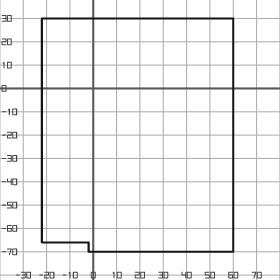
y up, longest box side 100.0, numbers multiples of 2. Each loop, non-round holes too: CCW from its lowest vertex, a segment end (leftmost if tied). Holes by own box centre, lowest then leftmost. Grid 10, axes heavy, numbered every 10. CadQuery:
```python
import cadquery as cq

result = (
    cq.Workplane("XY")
    .moveTo(-2.0, -70.0)
    .lineTo(60.0, -70.0)
    .lineTo(60.0, 30.0)
    .lineTo(-22.0, 30.0)
    .lineTo(-22.0, -66.0)
    .lineTo(-2.0, -66.0)
    .close()
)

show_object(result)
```